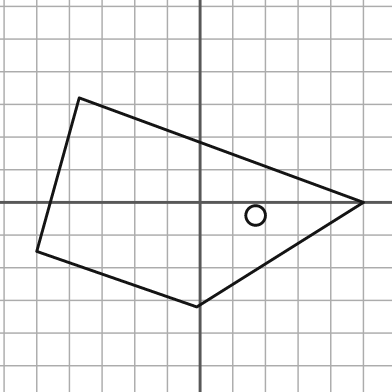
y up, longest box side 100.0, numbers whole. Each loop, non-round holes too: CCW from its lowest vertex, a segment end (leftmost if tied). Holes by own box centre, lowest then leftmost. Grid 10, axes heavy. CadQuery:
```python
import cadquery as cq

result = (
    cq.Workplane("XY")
    .moveTo(-1.0, -32.0)
    .lineTo(50.0, 0.0)
    .lineTo(-37.0, 32.0)
    .lineTo(-50.0, -15.0)
    .close()
    .moveTo(17.0, -4.0)
    .circle(3.0)
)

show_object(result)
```